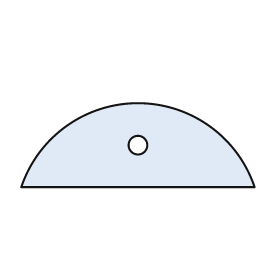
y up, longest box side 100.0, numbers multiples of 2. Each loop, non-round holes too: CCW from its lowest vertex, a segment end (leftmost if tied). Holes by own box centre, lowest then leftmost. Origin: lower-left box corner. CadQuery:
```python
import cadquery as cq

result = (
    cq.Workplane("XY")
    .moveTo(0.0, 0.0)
    .lineTo(100.0, 0.0)
    .threePointArc((50.0, 36.0), (0.0, 0.0))
    .close()
    .moveTo(50.0, 18.0)
    .circle(4.0)
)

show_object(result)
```